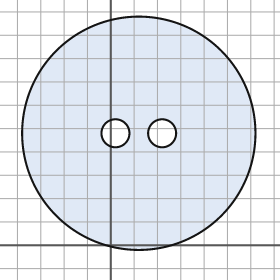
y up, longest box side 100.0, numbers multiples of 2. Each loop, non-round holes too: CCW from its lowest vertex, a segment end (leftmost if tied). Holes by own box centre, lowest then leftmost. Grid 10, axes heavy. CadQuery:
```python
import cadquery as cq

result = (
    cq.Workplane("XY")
    .moveTo(12.0, 48.0)
    .circle(50.0)
    .moveTo(2.0, 48.0)
    .circle(6.0)
    .moveTo(22.0, 48.0)
    .circle(6.0)
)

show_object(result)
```